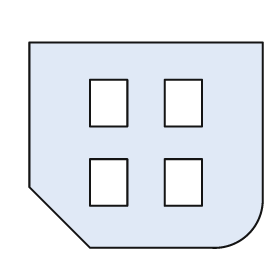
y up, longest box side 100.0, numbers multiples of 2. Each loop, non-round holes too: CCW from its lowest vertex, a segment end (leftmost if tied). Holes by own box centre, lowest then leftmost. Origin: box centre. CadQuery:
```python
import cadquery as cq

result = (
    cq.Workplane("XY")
    .moveTo(-24.0, -44.0)
    .lineTo(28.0, -44.0)
    .threePointArc((44.0, -38.0), (50.0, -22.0))
    .lineTo(50.0, 44.0)
    .lineTo(-50.0, 44.0)
    .lineTo(-50.0, -18.0)
    .close()
    .moveTo(-24.0, -26.0)
    .lineTo(-8.0, -26.0)
    .lineTo(-8.0, -6.0)
    .lineTo(-24.0, -6.0)
    .close()
    .moveTo(8.0, -26.0)
    .lineTo(24.0, -26.0)
    .lineTo(24.0, -6.0)
    .lineTo(8.0, -6.0)
    .close()
    .moveTo(-24.0, 8.0)
    .lineTo(-8.0, 8.0)
    .lineTo(-8.0, 28.0)
    .lineTo(-24.0, 28.0)
    .close()
    .moveTo(8.0, 8.0)
    .lineTo(24.0, 8.0)
    .lineTo(24.0, 28.0)
    .lineTo(8.0, 28.0)
    .close()
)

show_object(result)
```